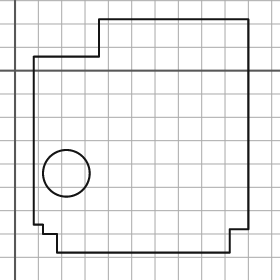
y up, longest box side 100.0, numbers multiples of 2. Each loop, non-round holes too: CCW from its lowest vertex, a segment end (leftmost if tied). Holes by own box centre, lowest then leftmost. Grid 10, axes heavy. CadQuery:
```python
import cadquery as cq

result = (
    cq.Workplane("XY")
    .moveTo(18.0, -78.0)
    .lineTo(92.0, -78.0)
    .lineTo(92.0, -68.0)
    .lineTo(100.0, -68.0)
    .lineTo(100.0, 22.0)
    .lineTo(36.0, 22.0)
    .lineTo(36.0, 6.0)
    .lineTo(8.0, 6.0)
    .lineTo(8.0, -66.0)
    .lineTo(12.0, -66.0)
    .lineTo(12.0, -70.0)
    .lineTo(18.0, -70.0)
    .close()
    .moveTo(22.0, -44.0)
    .circle(10.0)
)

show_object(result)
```